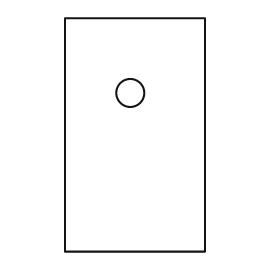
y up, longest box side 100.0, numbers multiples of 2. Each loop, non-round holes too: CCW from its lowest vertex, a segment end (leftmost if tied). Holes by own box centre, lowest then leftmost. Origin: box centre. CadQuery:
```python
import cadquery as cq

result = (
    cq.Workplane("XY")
    .moveTo(-30.0, -50.0)
    .lineTo(30.0, -50.0)
    .lineTo(30.0, 50.0)
    .lineTo(-30.0, 50.0)
    .close()
    .moveTo(-2.0, 18.0)
    .circle(6.0)
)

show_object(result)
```